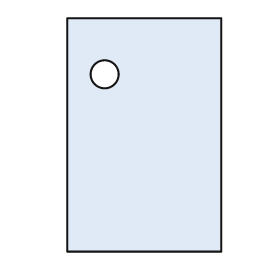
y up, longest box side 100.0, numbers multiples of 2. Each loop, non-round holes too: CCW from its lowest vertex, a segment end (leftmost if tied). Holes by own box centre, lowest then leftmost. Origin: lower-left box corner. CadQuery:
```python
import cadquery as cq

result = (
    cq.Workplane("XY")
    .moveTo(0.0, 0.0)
    .lineTo(66.0, 0.0)
    .lineTo(66.0, 100.0)
    .lineTo(0.0, 100.0)
    .close()
    .moveTo(16.0, 76.0)
    .circle(6.0)
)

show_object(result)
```